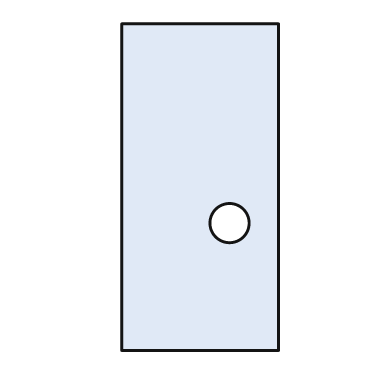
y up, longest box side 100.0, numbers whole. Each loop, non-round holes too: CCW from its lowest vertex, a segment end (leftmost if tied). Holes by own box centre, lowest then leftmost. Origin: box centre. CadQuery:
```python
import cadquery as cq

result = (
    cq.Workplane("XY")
    .moveTo(-24.0, -50.0)
    .lineTo(24.0, -50.0)
    .lineTo(24.0, 50.0)
    .lineTo(-24.0, 50.0)
    .close()
    .moveTo(9.0, -11.0)
    .circle(6.0)
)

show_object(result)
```